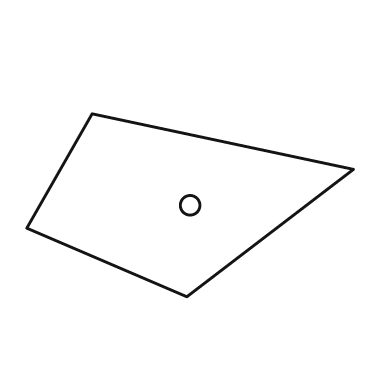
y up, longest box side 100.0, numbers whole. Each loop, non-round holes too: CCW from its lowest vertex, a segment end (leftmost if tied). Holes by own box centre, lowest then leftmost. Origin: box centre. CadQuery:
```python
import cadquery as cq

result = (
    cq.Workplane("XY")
    .moveTo(-1.0, -28.0)
    .lineTo(50.0, 11.0)
    .lineTo(-30.0, 28.0)
    .lineTo(-50.0, -7.0)
    .close()
    .moveTo(0.0, 0.0)
    .circle(3.0)
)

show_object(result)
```